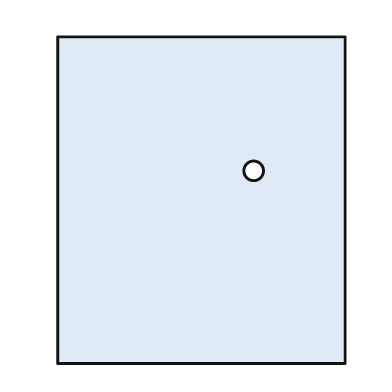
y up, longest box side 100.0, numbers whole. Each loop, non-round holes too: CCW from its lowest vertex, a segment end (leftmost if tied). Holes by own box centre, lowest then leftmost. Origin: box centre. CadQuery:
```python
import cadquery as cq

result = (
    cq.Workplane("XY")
    .moveTo(-44.0, -50.0)
    .lineTo(44.0, -50.0)
    .lineTo(44.0, 50.0)
    .lineTo(-44.0, 50.0)
    .close()
    .moveTo(16.0, 9.0)
    .circle(3.0)
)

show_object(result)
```